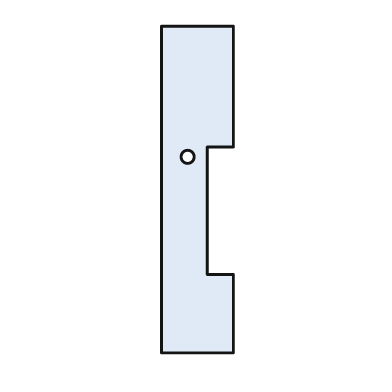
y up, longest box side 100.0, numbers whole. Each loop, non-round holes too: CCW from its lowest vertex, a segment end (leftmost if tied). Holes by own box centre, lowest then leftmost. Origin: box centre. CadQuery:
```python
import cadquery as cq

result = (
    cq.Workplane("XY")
    .moveTo(-11.0, -50.0)
    .lineTo(11.0, -50.0)
    .lineTo(11.0, -26.0)
    .lineTo(3.0, -26.0)
    .lineTo(3.0, 13.0)
    .lineTo(11.0, 13.0)
    .lineTo(11.0, 50.0)
    .lineTo(-11.0, 50.0)
    .close()
    .moveTo(-3.0, 10.0)
    .circle(2.0)
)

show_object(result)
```